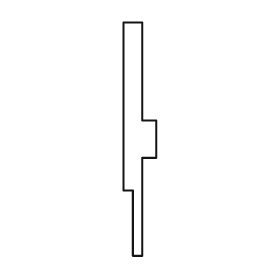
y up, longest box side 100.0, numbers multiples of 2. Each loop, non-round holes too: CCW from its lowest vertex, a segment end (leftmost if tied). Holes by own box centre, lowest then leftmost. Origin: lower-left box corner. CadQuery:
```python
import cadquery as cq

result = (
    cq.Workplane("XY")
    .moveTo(4.0, 0.0)
    .lineTo(8.0, 0.0)
    .lineTo(8.0, 42.0)
    .lineTo(14.0, 42.0)
    .lineTo(14.0, 58.0)
    .lineTo(8.0, 58.0)
    .lineTo(8.0, 100.0)
    .lineTo(0.0, 100.0)
    .lineTo(0.0, 28.0)
    .lineTo(4.0, 28.0)
    .close()
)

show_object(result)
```